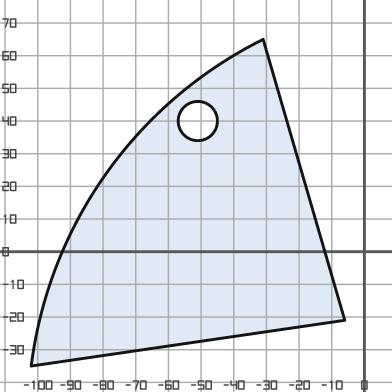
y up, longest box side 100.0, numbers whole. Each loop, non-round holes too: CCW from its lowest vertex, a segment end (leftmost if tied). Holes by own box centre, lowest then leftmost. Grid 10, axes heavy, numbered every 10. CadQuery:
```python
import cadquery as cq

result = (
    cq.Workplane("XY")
    .moveTo(-102.0, -35.0)
    .lineTo(-6.0, -21.0)
    .lineTo(-31.0, 65.0)
    .threePointArc((-79.0, 24.0), (-102.0, -35.0))
    .close()
    .moveTo(-51.0, 40.0)
    .circle(6.0)
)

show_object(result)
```